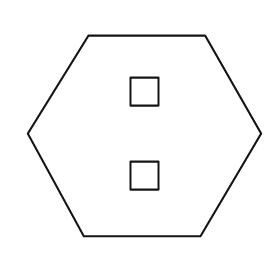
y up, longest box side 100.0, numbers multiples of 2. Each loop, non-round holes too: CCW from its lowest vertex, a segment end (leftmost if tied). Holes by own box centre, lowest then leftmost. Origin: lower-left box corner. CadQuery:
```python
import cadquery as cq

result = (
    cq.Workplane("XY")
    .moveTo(24.0, 0.0)
    .lineTo(74.0, 0.0)
    .lineTo(100.0, 44.0)
    .lineTo(76.0, 86.0)
    .lineTo(26.0, 86.0)
    .lineTo(0.0, 44.0)
    .close()
    .moveTo(44.0, 20.0)
    .lineTo(56.0, 20.0)
    .lineTo(56.0, 32.0)
    .lineTo(44.0, 32.0)
    .close()
    .moveTo(44.0, 56.0)
    .lineTo(56.0, 56.0)
    .lineTo(56.0, 68.0)
    .lineTo(44.0, 68.0)
    .close()
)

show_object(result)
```